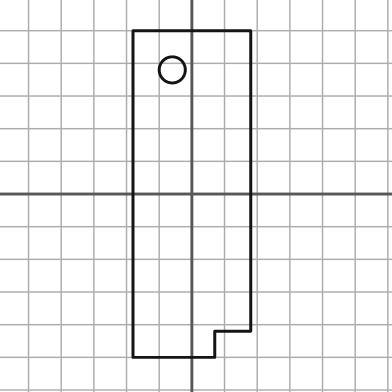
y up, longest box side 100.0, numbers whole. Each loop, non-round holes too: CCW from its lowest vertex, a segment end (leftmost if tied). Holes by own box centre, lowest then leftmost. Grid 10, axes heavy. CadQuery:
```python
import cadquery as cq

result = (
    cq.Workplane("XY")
    .moveTo(-18.0, -50.0)
    .lineTo(7.0, -50.0)
    .lineTo(7.0, -42.0)
    .lineTo(18.0, -42.0)
    .lineTo(18.0, 50.0)
    .lineTo(-18.0, 50.0)
    .close()
    .moveTo(-6.0, 38.0)
    .circle(4.0)
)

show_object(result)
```